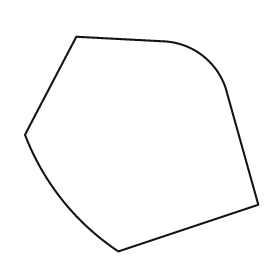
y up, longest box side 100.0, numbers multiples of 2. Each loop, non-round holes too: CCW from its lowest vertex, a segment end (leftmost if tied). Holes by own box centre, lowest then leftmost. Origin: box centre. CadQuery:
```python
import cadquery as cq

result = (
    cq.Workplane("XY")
    .moveTo(-10.0, -46.0)
    .lineTo(50.0, -26.0)
    .lineTo(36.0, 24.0)
    .threePointArc((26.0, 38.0), (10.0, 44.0))
    .lineTo(-28.0, 46.0)
    .lineTo(-50.0, 4.0)
    .threePointArc((-34.0, -24.0), (-10.0, -46.0))
    .close()
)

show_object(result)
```